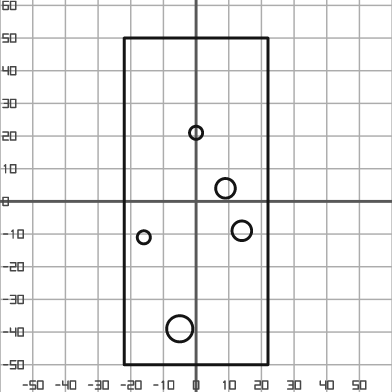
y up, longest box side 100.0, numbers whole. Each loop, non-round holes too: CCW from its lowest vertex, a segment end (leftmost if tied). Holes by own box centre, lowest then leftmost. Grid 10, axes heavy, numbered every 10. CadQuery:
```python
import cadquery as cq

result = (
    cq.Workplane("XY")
    .moveTo(-22.0, -50.0)
    .lineTo(22.0, -50.0)
    .lineTo(22.0, 50.0)
    .lineTo(-22.0, 50.0)
    .close()
    .moveTo(-5.0, -39.0)
    .circle(4.0)
    .moveTo(-16.0, -11.0)
    .circle(2.0)
    .moveTo(14.0, -9.0)
    .circle(3.0)
    .moveTo(9.0, 4.0)
    .circle(3.0)
    .moveTo(0.0, 21.0)
    .circle(2.0)
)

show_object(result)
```